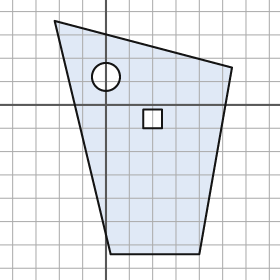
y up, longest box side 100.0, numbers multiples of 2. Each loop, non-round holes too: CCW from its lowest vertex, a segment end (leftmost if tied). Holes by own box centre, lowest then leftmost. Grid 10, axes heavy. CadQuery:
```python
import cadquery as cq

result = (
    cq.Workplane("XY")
    .moveTo(2.0, -64.0)
    .lineTo(40.0, -64.0)
    .lineTo(54.0, 16.0)
    .lineTo(-22.0, 36.0)
    .close()
    .moveTo(16.0, -10.0)
    .lineTo(24.0, -10.0)
    .lineTo(24.0, -2.0)
    .lineTo(16.0, -2.0)
    .close()
    .moveTo(0.0, 12.0)
    .circle(6.0)
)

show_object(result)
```